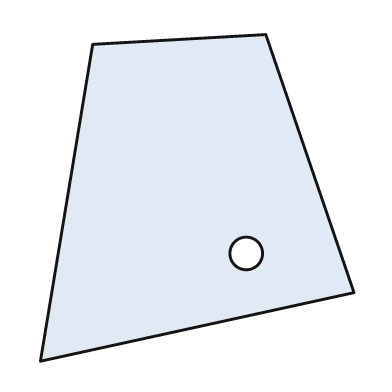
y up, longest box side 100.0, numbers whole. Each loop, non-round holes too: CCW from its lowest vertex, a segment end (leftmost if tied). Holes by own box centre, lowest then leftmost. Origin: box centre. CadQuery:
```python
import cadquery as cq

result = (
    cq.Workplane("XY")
    .moveTo(-48.0, -50.0)
    .lineTo(48.0, -29.0)
    .lineTo(21.0, 50.0)
    .lineTo(-32.0, 47.0)
    .close()
    .moveTo(15.0, -17.0)
    .circle(5.0)
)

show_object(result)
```